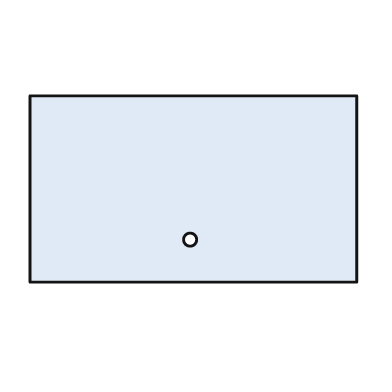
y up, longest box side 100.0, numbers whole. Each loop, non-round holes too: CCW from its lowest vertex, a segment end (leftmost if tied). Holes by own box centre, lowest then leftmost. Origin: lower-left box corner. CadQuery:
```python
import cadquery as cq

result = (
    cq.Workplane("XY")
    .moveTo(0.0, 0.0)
    .lineTo(100.0, 0.0)
    .lineTo(100.0, 57.0)
    .lineTo(0.0, 57.0)
    .close()
    .moveTo(49.0, 13.0)
    .circle(2.0)
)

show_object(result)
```